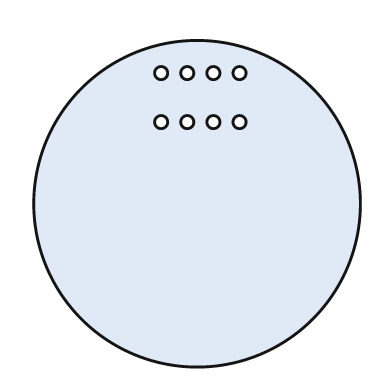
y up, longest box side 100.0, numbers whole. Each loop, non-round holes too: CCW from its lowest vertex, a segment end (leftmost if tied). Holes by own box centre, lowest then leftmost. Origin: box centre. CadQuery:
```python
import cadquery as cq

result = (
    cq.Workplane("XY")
    .moveTo(0.0, 0.0)
    .circle(50.0)
    .moveTo(-11.0, 25.0)
    .circle(2.0)
    .moveTo(-3.0, 25.0)
    .circle(2.0)
    .moveTo(5.0, 25.0)
    .circle(2.0)
    .moveTo(13.0, 25.0)
    .circle(2.0)
    .moveTo(-11.0, 40.0)
    .circle(2.0)
    .moveTo(-3.0, 40.0)
    .circle(2.0)
    .moveTo(5.0, 40.0)
    .circle(2.0)
    .moveTo(13.0, 40.0)
    .circle(2.0)
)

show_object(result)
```